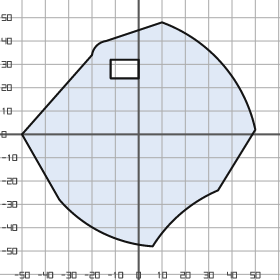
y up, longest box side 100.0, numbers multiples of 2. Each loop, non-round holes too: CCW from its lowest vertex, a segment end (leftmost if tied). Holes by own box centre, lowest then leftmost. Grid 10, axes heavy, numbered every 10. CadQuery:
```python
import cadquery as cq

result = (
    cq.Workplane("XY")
    .moveTo(6.0, -48.0)
    .threePointArc((18.0, -34.0), (34.0, -24.0))
    .lineTo(50.0, 2.0)
    .threePointArc((36.0, 30.0), (10.0, 48.0))
    .lineTo(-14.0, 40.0)
    .threePointArc((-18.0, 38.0), (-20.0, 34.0))
    .lineTo(-50.0, 0.0)
    .lineTo(-34.0, -28.0)
    .threePointArc((-16.0, -42.0), (6.0, -48.0))
    .close()
    .moveTo(-12.0, 24.0)
    .lineTo(0.0, 24.0)
    .lineTo(0.0, 32.0)
    .lineTo(-12.0, 32.0)
    .close()
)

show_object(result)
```